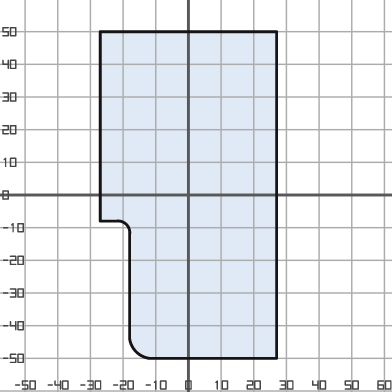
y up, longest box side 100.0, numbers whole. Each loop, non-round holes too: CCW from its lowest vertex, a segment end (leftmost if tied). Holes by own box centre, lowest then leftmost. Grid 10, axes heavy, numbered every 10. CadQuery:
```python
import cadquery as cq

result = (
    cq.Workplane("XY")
    .moveTo(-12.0, -50.0)
    .lineTo(27.0, -50.0)
    .lineTo(27.0, 50.0)
    .lineTo(-27.0, 50.0)
    .lineTo(-27.0, -8.0)
    .lineTo(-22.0, -8.0)
    .threePointArc((-19.0, -9.0), (-18.0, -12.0))
    .lineTo(-18.0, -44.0)
    .threePointArc((-16.0, -48.0), (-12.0, -50.0))
    .close()
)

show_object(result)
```